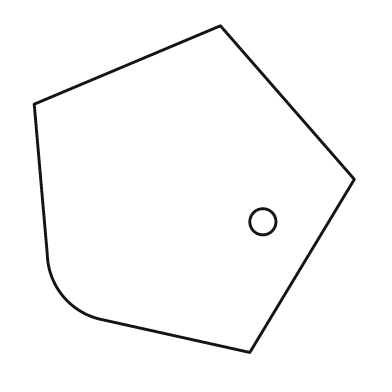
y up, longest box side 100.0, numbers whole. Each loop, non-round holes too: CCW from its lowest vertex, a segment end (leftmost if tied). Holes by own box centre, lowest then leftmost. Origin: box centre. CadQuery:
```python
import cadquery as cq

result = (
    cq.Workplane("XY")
    .moveTo(17.0, -50.0)
    .lineTo(49.0, 3.0)
    .lineTo(8.0, 50.0)
    .lineTo(-49.0, 26.0)
    .lineTo(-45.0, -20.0)
    .threePointArc((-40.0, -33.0), (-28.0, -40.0))
    .close()
    .moveTo(21.0, -10.0)
    .circle(4.0)
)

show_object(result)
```